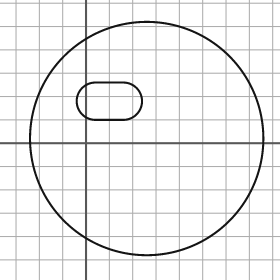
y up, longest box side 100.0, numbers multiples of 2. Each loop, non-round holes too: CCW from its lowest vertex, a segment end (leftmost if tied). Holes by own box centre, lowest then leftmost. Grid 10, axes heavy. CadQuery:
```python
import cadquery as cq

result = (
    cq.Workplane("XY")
    .moveTo(26.0, 2.0)
    .circle(50.0)
    .moveTo(4.0, 10.0)
    .lineTo(16.0, 10.0)
    .threePointArc((24.0, 18.0), (16.0, 26.0))
    .lineTo(4.0, 26.0)
    .threePointArc((-4.0, 18.0), (4.0, 10.0))
    .close()
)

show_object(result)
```